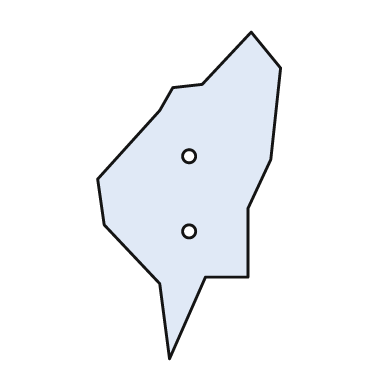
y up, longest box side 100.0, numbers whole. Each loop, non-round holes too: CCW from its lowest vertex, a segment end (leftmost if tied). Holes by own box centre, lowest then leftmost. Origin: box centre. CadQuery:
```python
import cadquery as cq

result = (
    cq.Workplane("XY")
    .moveTo(-6.0, -50.0)
    .lineTo(5.0, -25.0)
    .lineTo(18.0, -25.0)
    .lineTo(18.0, -4.0)
    .lineTo(25.0, 11.0)
    .lineTo(28.0, 39.0)
    .lineTo(19.0, 50.0)
    .lineTo(4.0, 34.0)
    .lineTo(-5.0, 33.0)
    .lineTo(-9.0, 26.0)
    .lineTo(-28.0, 5.0)
    .lineTo(-26.0, -9.0)
    .lineTo(-9.0, -27.0)
    .close()
    .moveTo(0.0, -11.0)
    .circle(2.0)
    .moveTo(0.0, 12.0)
    .circle(2.0)
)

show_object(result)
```